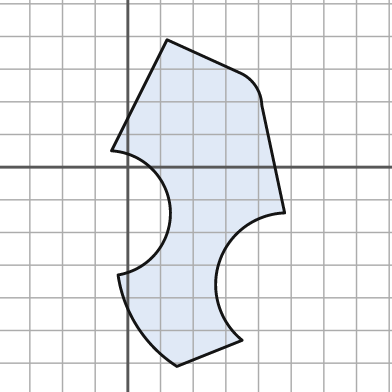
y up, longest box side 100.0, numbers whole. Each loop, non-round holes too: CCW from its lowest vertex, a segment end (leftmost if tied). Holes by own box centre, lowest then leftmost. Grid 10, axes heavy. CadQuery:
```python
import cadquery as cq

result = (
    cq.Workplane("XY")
    .moveTo(15.0, -61.0)
    .lineTo(35.0, -53.0)
    .threePointArc((28.0, -29.0), (48.0, -14.0))
    .lineTo(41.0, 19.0)
    .threePointArc((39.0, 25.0), (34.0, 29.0))
    .lineTo(12.0, 39.0)
    .lineTo(-5.0, 5.0)
    .threePointArc((13.0, -13.0), (-3.0, -33.0))
    .threePointArc((3.0, -49.0), (15.0, -61.0))
    .close()
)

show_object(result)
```